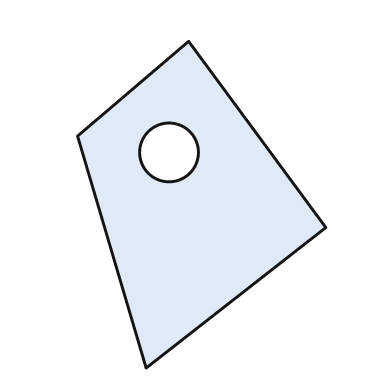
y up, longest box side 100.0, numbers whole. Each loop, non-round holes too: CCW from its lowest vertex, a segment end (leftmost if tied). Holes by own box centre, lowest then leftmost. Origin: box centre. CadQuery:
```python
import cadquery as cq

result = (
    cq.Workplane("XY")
    .moveTo(-17.0, -50.0)
    .lineTo(38.0, -7.0)
    .lineTo(-4.0, 50.0)
    .lineTo(-38.0, 21.0)
    .close()
    .moveTo(-10.0, 16.0)
    .circle(9.0)
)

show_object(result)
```